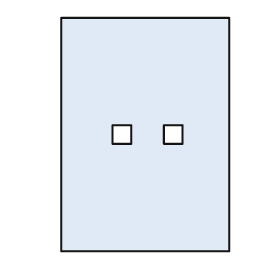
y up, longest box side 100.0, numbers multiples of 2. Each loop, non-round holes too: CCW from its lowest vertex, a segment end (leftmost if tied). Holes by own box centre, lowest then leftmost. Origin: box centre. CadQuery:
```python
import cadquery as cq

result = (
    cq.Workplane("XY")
    .moveTo(-36.0, -50.0)
    .lineTo(36.0, -50.0)
    .lineTo(36.0, 50.0)
    .lineTo(-36.0, 50.0)
    .close()
    .moveTo(-14.0, -4.0)
    .lineTo(-6.0, -4.0)
    .lineTo(-6.0, 4.0)
    .lineTo(-14.0, 4.0)
    .close()
    .moveTo(8.0, -4.0)
    .lineTo(16.0, -4.0)
    .lineTo(16.0, 4.0)
    .lineTo(8.0, 4.0)
    .close()
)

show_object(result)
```